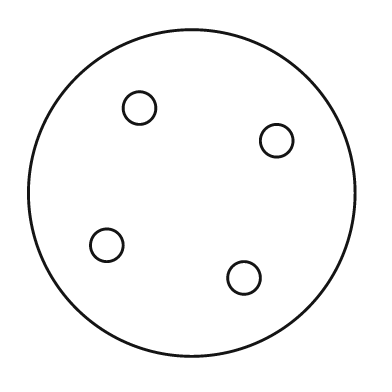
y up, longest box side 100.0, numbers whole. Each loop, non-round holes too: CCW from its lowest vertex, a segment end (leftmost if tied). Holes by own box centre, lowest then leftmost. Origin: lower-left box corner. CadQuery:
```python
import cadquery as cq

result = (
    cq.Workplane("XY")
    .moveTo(50.0, 50.0)
    .circle(50.0)
    .moveTo(66.0, 24.0)
    .circle(5.0)
    .moveTo(24.0, 34.0)
    .circle(5.0)
    .moveTo(76.0, 66.0)
    .circle(5.0)
    .moveTo(34.0, 76.0)
    .circle(5.0)
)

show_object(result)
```